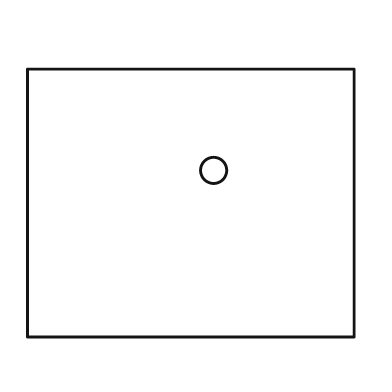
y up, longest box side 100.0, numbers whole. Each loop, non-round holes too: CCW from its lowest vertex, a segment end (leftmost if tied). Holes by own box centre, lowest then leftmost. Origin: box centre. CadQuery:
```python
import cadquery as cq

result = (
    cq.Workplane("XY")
    .moveTo(-50.0, -41.0)
    .lineTo(50.0, -41.0)
    .lineTo(50.0, 41.0)
    .lineTo(-50.0, 41.0)
    .close()
    .moveTo(7.0, 10.0)
    .circle(4.0)
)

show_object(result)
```